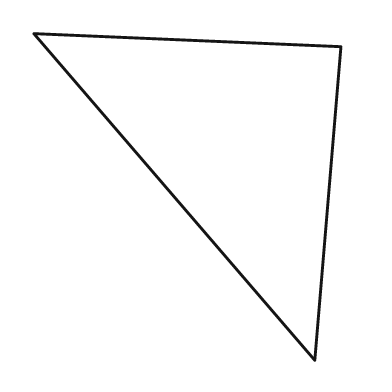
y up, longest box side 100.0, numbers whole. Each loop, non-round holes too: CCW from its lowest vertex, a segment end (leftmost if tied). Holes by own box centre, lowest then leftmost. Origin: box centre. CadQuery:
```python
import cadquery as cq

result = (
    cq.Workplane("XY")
    .moveTo(39.0, -50.0)
    .lineTo(47.0, 46.0)
    .lineTo(-47.0, 50.0)
    .close()
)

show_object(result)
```